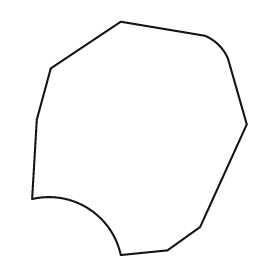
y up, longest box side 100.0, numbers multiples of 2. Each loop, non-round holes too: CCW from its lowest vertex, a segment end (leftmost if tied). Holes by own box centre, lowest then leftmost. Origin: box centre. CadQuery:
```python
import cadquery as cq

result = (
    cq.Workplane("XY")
    .moveTo(-8.0, -50.0)
    .lineTo(12.0, -48.0)
    .lineTo(26.0, -38.0)
    .lineTo(46.0, 6.0)
    .lineTo(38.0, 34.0)
    .threePointArc((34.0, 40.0), (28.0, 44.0))
    .lineTo(-8.0, 50.0)
    .lineTo(-38.0, 30.0)
    .lineTo(-44.0, 8.0)
    .lineTo(-46.0, -26.0)
    .threePointArc((-22.0, -30.0), (-8.0, -50.0))
    .close()
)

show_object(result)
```